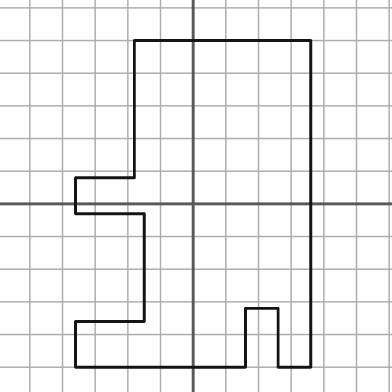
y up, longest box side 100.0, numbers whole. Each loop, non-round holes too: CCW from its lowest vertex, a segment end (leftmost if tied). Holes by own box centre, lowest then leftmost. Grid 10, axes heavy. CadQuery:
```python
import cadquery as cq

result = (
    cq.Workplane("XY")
    .moveTo(-36.0, -50.0)
    .lineTo(16.0, -50.0)
    .lineTo(16.0, -32.0)
    .lineTo(26.0, -32.0)
    .lineTo(26.0, -50.0)
    .lineTo(36.0, -50.0)
    .lineTo(36.0, 50.0)
    .lineTo(-18.0, 50.0)
    .lineTo(-18.0, 8.0)
    .lineTo(-36.0, 8.0)
    .lineTo(-36.0, -3.0)
    .lineTo(-15.0, -3.0)
    .lineTo(-15.0, -36.0)
    .lineTo(-36.0, -36.0)
    .close()
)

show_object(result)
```